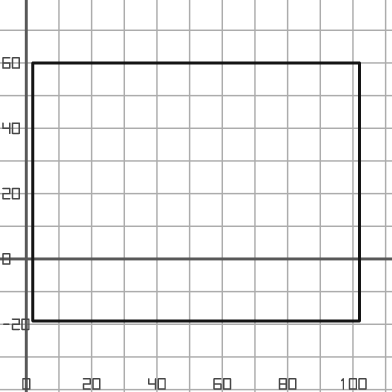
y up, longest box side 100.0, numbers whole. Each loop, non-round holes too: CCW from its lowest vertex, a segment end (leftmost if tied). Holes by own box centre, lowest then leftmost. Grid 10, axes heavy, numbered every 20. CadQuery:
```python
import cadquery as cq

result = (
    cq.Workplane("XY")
    .moveTo(2.0, -19.0)
    .lineTo(102.0, -19.0)
    .lineTo(102.0, 60.0)
    .lineTo(2.0, 60.0)
    .close()
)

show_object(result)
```